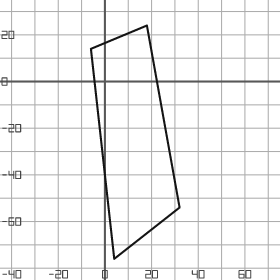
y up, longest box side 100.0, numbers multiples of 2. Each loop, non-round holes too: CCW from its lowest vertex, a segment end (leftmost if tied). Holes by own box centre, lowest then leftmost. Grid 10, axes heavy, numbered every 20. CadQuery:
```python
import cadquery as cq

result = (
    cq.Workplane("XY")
    .moveTo(4.0, -76.0)
    .lineTo(32.0, -54.0)
    .lineTo(18.0, 24.0)
    .lineTo(-6.0, 14.0)
    .close()
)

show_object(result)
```